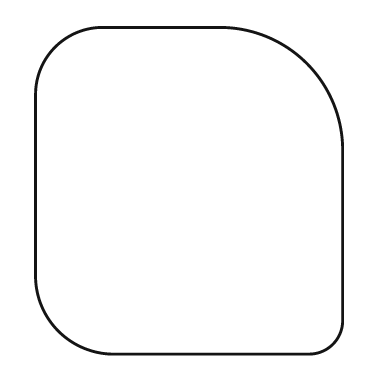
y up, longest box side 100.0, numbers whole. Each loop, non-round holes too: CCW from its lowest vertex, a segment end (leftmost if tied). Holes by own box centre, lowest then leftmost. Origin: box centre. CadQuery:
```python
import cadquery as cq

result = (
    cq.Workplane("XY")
    .moveTo(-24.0, -50.0)
    .lineTo(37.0, -50.0)
    .threePointArc((44.0, -47.0), (47.0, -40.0))
    .lineTo(47.0, 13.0)
    .threePointArc((36.0, 39.0), (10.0, 50.0))
    .lineTo(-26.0, 50.0)
    .threePointArc((-41.0, 44.0), (-47.0, 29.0))
    .lineTo(-47.0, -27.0)
    .threePointArc((-40.0, -43.0), (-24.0, -50.0))
    .close()
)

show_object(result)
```